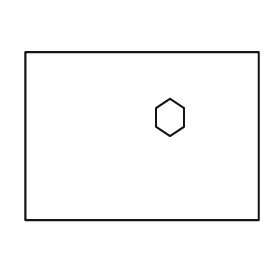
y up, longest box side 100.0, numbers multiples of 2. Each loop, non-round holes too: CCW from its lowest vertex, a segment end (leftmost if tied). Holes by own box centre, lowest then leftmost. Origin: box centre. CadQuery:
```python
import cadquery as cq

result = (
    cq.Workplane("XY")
    .moveTo(-50.0, -36.0)
    .lineTo(50.0, -36.0)
    .lineTo(50.0, 36.0)
    .lineTo(-50.0, 36.0)
    .close()
    .moveTo(12.0, 0.0)
    .lineTo(18.0, 4.0)
    .lineTo(18.0, 12.0)
    .lineTo(12.0, 16.0)
    .lineTo(6.0, 12.0)
    .lineTo(6.0, 4.0)
    .close()
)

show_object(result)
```